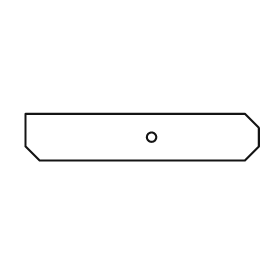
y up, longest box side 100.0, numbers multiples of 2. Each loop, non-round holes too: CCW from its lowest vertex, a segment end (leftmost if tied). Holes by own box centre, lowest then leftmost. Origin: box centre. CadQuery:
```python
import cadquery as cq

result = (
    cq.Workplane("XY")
    .moveTo(-44.0, -10.0)
    .lineTo(44.0, -10.0)
    .lineTo(50.0, -4.0)
    .lineTo(50.0, 4.0)
    .lineTo(44.0, 10.0)
    .lineTo(-50.0, 10.0)
    .lineTo(-50.0, -4.0)
    .close()
    .moveTo(4.0, 0.0)
    .circle(2.0)
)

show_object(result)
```